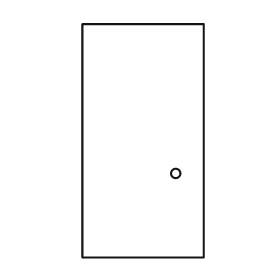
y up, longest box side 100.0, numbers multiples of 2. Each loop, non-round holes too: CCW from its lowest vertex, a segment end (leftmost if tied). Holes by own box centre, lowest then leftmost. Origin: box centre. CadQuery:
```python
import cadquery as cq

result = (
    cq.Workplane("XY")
    .moveTo(-26.0, -50.0)
    .lineTo(26.0, -50.0)
    .lineTo(26.0, 50.0)
    .lineTo(-26.0, 50.0)
    .close()
    .moveTo(14.0, -14.0)
    .circle(2.0)
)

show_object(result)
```